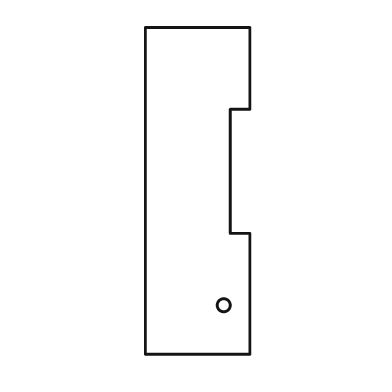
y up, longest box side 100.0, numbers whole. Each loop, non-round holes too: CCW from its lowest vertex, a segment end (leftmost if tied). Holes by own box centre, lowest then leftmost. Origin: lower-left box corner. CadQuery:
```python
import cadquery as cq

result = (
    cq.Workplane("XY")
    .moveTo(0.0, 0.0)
    .lineTo(32.0, 0.0)
    .lineTo(32.0, 37.0)
    .lineTo(26.0, 37.0)
    .lineTo(26.0, 75.0)
    .lineTo(32.0, 75.0)
    .lineTo(32.0, 100.0)
    .lineTo(0.0, 100.0)
    .close()
    .moveTo(24.0, 15.0)
    .circle(2.0)
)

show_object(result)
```